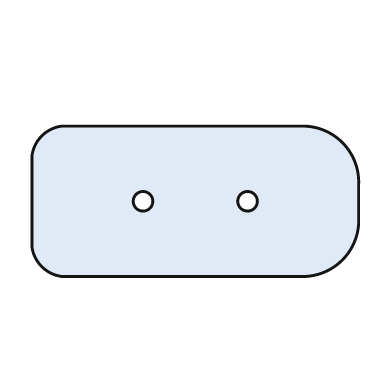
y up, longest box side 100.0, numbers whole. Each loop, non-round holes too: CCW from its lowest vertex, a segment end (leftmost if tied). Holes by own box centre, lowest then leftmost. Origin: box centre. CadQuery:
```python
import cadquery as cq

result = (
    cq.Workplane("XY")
    .moveTo(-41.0, -23.0)
    .lineTo(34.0, -23.0)
    .threePointArc((45.0, -18.0), (50.0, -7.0))
    .lineTo(50.0, 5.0)
    .threePointArc((45.0, 18.0), (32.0, 23.0))
    .lineTo(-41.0, 23.0)
    .threePointArc((-47.0, 20.0), (-50.0, 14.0))
    .lineTo(-50.0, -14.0)
    .threePointArc((-47.0, -20.0), (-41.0, -23.0))
    .close()
    .moveTo(-16.0, 0.0)
    .circle(3.0)
    .moveTo(16.0, 0.0)
    .circle(3.0)
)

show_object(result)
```